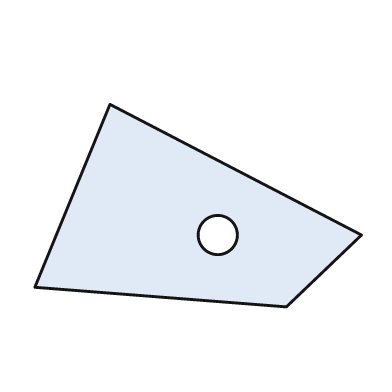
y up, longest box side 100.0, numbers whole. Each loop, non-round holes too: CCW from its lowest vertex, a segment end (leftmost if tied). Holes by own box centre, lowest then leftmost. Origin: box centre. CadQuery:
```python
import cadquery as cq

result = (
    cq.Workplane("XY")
    .moveTo(27.0, -31.0)
    .lineTo(50.0, -9.0)
    .lineTo(-27.0, 31.0)
    .lineTo(-50.0, -25.0)
    .close()
    .moveTo(6.0, -9.0)
    .circle(6.0)
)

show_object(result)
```